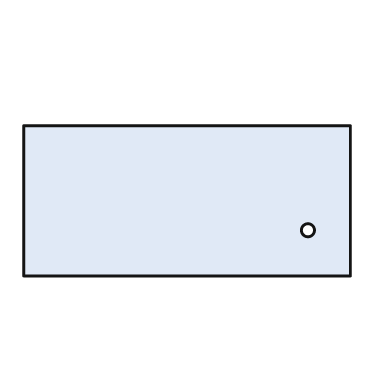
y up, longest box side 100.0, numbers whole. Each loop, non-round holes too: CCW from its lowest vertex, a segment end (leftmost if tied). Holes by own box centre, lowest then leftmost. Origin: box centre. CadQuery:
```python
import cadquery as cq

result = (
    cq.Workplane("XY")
    .moveTo(-50.0, -23.0)
    .lineTo(50.0, -23.0)
    .lineTo(50.0, 23.0)
    .lineTo(-50.0, 23.0)
    .close()
    .moveTo(37.0, -9.0)
    .circle(2.0)
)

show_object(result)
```